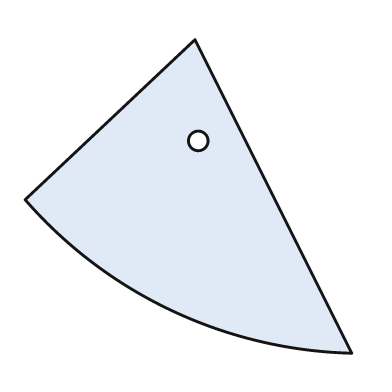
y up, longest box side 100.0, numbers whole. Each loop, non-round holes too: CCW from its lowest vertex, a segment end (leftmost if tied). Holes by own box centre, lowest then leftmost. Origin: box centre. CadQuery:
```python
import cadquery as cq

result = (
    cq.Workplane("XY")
    .moveTo(50.0, -48.0)
    .lineTo(2.0, 48.0)
    .lineTo(-50.0, -1.0)
    .threePointArc((-5.0, -35.0), (50.0, -48.0))
    .close()
    .moveTo(3.0, 17.0)
    .circle(3.0)
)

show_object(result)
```